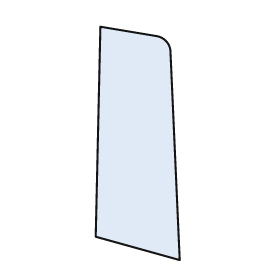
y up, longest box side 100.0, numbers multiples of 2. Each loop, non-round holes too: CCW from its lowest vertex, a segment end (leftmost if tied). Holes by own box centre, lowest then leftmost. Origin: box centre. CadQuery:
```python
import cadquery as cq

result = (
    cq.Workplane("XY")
    .moveTo(18.0, -50.0)
    .lineTo(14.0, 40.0)
    .threePointArc((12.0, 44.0), (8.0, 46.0))
    .lineTo(-16.0, 50.0)
    .lineTo(-18.0, -40.0)
    .close()
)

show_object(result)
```